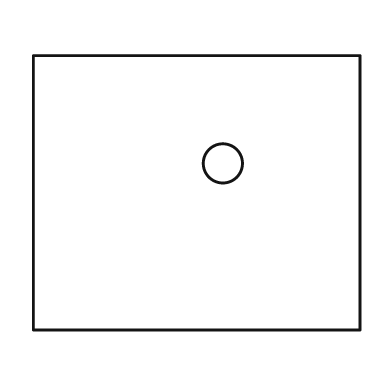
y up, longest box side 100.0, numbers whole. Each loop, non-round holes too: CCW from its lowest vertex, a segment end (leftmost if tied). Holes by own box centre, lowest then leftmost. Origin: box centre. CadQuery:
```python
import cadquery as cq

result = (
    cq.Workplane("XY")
    .moveTo(-50.0, -42.0)
    .lineTo(50.0, -42.0)
    .lineTo(50.0, 42.0)
    .lineTo(-50.0, 42.0)
    .close()
    .moveTo(8.0, 9.0)
    .circle(6.0)
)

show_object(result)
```